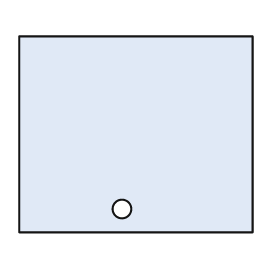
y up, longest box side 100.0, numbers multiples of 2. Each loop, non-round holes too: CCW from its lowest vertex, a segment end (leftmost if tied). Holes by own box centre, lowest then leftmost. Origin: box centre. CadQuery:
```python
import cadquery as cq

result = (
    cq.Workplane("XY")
    .moveTo(-50.0, -42.0)
    .lineTo(50.0, -42.0)
    .lineTo(50.0, 42.0)
    .lineTo(-50.0, 42.0)
    .close()
    .moveTo(-6.0, -32.0)
    .circle(4.0)
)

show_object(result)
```